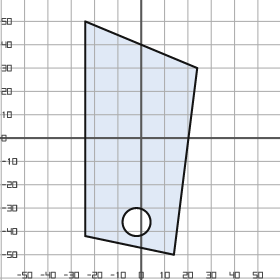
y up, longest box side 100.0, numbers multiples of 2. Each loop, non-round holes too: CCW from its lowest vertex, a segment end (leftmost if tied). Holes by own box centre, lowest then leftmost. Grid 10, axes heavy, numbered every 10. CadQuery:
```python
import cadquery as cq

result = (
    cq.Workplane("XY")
    .moveTo(14.0, -50.0)
    .lineTo(24.0, 30.0)
    .lineTo(-24.0, 50.0)
    .lineTo(-24.0, -42.0)
    .close()
    .moveTo(-2.0, -36.0)
    .circle(6.0)
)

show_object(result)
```